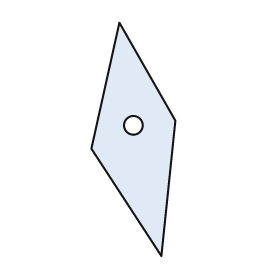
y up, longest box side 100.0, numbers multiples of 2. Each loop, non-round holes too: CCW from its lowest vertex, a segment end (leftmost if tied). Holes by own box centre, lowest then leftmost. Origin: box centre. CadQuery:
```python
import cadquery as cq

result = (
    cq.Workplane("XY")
    .moveTo(12.0, -50.0)
    .lineTo(18.0, 8.0)
    .lineTo(-6.0, 50.0)
    .lineTo(-18.0, -4.0)
    .close()
    .moveTo(0.0, 6.0)
    .circle(4.0)
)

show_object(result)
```